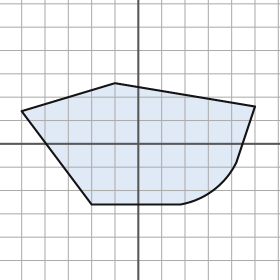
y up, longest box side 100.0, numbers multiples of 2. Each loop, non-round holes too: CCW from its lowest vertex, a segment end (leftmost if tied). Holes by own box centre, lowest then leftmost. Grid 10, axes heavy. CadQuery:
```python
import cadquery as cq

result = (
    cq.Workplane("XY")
    .moveTo(-20.0, -26.0)
    .lineTo(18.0, -26.0)
    .threePointArc((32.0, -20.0), (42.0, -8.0))
    .lineTo(50.0, 16.0)
    .lineTo(-10.0, 26.0)
    .lineTo(-50.0, 14.0)
    .close()
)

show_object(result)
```